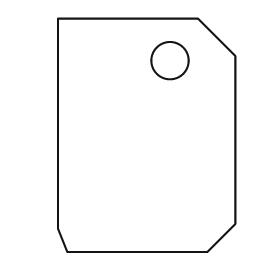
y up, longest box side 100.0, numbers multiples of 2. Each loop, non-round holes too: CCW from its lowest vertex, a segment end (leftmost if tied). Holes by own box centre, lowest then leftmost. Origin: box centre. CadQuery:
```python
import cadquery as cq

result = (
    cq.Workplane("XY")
    .moveTo(-34.0, -50.0)
    .lineTo(26.0, -50.0)
    .lineTo(38.0, -38.0)
    .lineTo(38.0, 34.0)
    .lineTo(22.0, 50.0)
    .lineTo(-38.0, 50.0)
    .lineTo(-38.0, -40.0)
    .close()
    .moveTo(10.0, 32.0)
    .circle(8.0)
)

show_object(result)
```